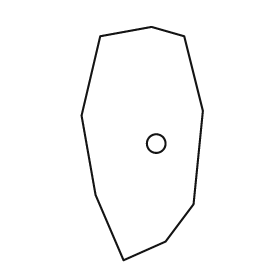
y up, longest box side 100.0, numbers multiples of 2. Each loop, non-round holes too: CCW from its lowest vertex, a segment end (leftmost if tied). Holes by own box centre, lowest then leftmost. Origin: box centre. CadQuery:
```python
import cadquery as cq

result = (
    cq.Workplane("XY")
    .moveTo(-8.0, -50.0)
    .lineTo(10.0, -42.0)
    .lineTo(22.0, -26.0)
    .lineTo(26.0, 14.0)
    .lineTo(18.0, 46.0)
    .lineTo(4.0, 50.0)
    .lineTo(-18.0, 46.0)
    .lineTo(-26.0, 12.0)
    .lineTo(-20.0, -22.0)
    .close()
    .moveTo(6.0, 0.0)
    .circle(4.0)
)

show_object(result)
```